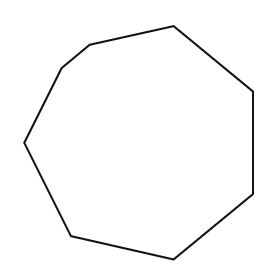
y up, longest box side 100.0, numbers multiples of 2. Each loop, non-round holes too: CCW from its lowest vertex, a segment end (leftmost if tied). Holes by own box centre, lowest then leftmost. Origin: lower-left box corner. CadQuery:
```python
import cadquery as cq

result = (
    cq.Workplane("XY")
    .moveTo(64.0, 0.0)
    .lineTo(98.0, 28.0)
    .lineTo(98.0, 72.0)
    .lineTo(64.0, 100.0)
    .lineTo(28.0, 92.0)
    .lineTo(16.0, 82.0)
    .lineTo(0.0, 50.0)
    .lineTo(20.0, 10.0)
    .close()
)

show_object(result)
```